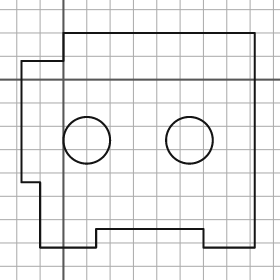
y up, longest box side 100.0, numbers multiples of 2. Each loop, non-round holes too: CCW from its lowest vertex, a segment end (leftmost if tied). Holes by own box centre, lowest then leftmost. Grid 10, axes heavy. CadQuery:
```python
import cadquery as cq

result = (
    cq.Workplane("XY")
    .moveTo(-10.0, -72.0)
    .lineTo(14.0, -72.0)
    .lineTo(14.0, -64.0)
    .lineTo(60.0, -64.0)
    .lineTo(60.0, -72.0)
    .lineTo(82.0, -72.0)
    .lineTo(82.0, 20.0)
    .lineTo(0.0, 20.0)
    .lineTo(0.0, 8.0)
    .lineTo(-18.0, 8.0)
    .lineTo(-18.0, -44.0)
    .lineTo(-10.0, -44.0)
    .close()
    .moveTo(10.0, -26.0)
    .circle(10.0)
    .moveTo(54.0, -26.0)
    .circle(10.0)
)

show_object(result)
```